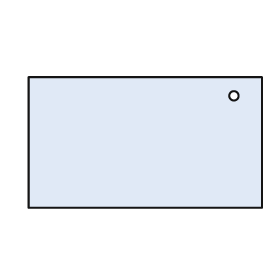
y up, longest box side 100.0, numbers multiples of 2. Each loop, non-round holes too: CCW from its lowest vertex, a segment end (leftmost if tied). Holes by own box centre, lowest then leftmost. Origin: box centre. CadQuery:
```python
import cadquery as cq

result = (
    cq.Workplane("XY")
    .moveTo(-50.0, -28.0)
    .lineTo(50.0, -28.0)
    .lineTo(50.0, 28.0)
    .lineTo(-50.0, 28.0)
    .close()
    .moveTo(38.0, 20.0)
    .circle(2.0)
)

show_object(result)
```